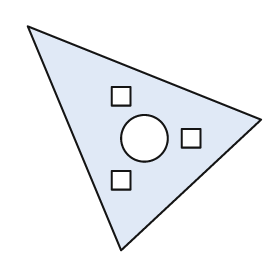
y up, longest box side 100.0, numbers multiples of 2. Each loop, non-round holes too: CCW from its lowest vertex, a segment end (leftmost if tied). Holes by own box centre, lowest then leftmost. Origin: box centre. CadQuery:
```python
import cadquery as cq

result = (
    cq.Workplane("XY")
    .moveTo(-10.0, -48.0)
    .lineTo(50.0, 8.0)
    .lineTo(-50.0, 48.0)
    .close()
    .moveTo(-14.0, -22.0)
    .lineTo(-6.0, -22.0)
    .lineTo(-6.0, -14.0)
    .lineTo(-14.0, -14.0)
    .close()
    .moveTo(0.0, 0.0)
    .circle(10.0)
    .moveTo(16.0, -4.0)
    .lineTo(24.0, -4.0)
    .lineTo(24.0, 4.0)
    .lineTo(16.0, 4.0)
    .close()
    .moveTo(-14.0, 14.0)
    .lineTo(-6.0, 14.0)
    .lineTo(-6.0, 22.0)
    .lineTo(-14.0, 22.0)
    .close()
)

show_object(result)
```